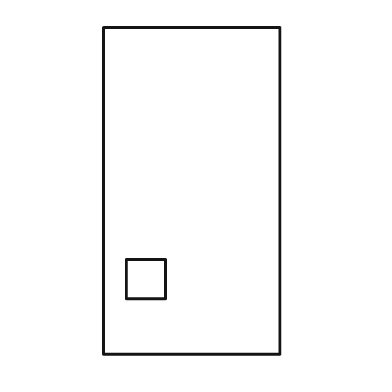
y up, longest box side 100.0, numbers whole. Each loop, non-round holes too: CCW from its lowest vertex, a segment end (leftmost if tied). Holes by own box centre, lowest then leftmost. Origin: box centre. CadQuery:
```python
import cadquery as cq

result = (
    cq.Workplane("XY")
    .moveTo(-27.0, -50.0)
    .lineTo(27.0, -50.0)
    .lineTo(27.0, 50.0)
    .lineTo(-27.0, 50.0)
    .close()
    .moveTo(-20.0, -33.0)
    .lineTo(-8.0, -33.0)
    .lineTo(-8.0, -21.0)
    .lineTo(-20.0, -21.0)
    .close()
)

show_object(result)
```